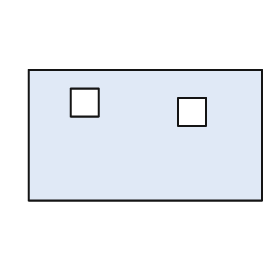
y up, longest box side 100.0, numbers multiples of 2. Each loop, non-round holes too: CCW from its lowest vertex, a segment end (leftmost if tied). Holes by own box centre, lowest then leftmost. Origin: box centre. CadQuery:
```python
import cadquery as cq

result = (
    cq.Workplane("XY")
    .moveTo(-50.0, -28.0)
    .lineTo(50.0, -28.0)
    .lineTo(50.0, 28.0)
    .lineTo(-50.0, 28.0)
    .close()
    .moveTo(14.0, 4.0)
    .lineTo(26.0, 4.0)
    .lineTo(26.0, 16.0)
    .lineTo(14.0, 16.0)
    .close()
    .moveTo(-32.0, 8.0)
    .lineTo(-20.0, 8.0)
    .lineTo(-20.0, 20.0)
    .lineTo(-32.0, 20.0)
    .close()
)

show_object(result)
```